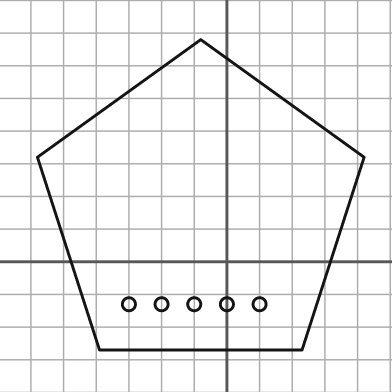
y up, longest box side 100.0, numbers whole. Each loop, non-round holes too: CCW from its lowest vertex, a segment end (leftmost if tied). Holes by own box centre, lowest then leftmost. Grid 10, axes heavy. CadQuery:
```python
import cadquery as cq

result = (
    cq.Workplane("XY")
    .moveTo(-39.0, -27.0)
    .lineTo(23.0, -27.0)
    .lineTo(42.0, 32.0)
    .lineTo(-8.0, 68.0)
    .lineTo(-58.0, 32.0)
    .close()
    .moveTo(-30.0, -13.0)
    .circle(2.0)
    .moveTo(-20.0, -13.0)
    .circle(2.0)
    .moveTo(-10.0, -13.0)
    .circle(2.0)
    .moveTo(0.0, -13.0)
    .circle(2.0)
    .moveTo(10.0, -13.0)
    .circle(2.0)
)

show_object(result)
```